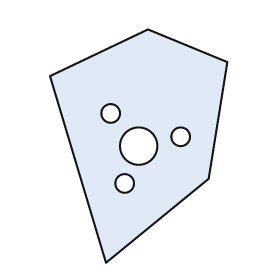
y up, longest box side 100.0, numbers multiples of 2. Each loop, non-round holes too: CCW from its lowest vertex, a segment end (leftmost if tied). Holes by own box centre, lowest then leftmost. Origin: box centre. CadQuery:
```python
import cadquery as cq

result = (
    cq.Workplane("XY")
    .moveTo(-14.0, -50.0)
    .lineTo(30.0, -14.0)
    .lineTo(38.0, 36.0)
    .lineTo(4.0, 50.0)
    .lineTo(-38.0, 30.0)
    .close()
    .moveTo(-6.0, -16.0)
    .circle(4.0)
    .moveTo(0.0, 0.0)
    .circle(8.0)
    .moveTo(18.0, 4.0)
    .circle(4.0)
    .moveTo(-12.0, 14.0)
    .circle(4.0)
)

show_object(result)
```